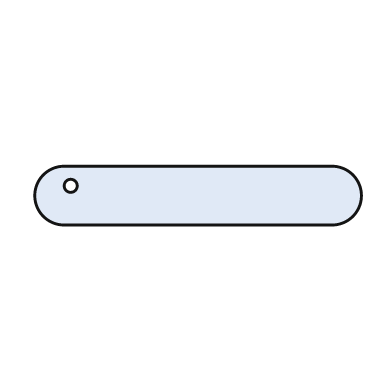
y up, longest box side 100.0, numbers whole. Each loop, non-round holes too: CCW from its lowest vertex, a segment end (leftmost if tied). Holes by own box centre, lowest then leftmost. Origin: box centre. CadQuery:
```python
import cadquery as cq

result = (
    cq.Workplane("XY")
    .moveTo(-41.0, -9.0)
    .lineTo(41.0, -9.0)
    .threePointArc((50.0, 0.0), (41.0, 9.0))
    .lineTo(-41.0, 9.0)
    .threePointArc((-50.0, 0.0), (-41.0, -9.0))
    .close()
    .moveTo(-39.0, 3.0)
    .circle(2.0)
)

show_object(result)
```